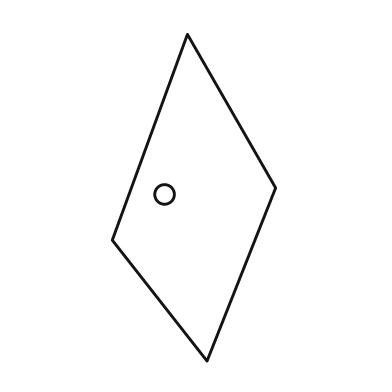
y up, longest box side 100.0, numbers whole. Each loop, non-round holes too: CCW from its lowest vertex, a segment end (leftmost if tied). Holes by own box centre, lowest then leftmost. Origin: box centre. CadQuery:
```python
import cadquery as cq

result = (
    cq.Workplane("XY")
    .moveTo(4.0, -50.0)
    .lineTo(25.0, 3.0)
    .lineTo(-2.0, 50.0)
    .lineTo(-25.0, -13.0)
    .close()
    .moveTo(-9.0, 1.0)
    .circle(3.0)
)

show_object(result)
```